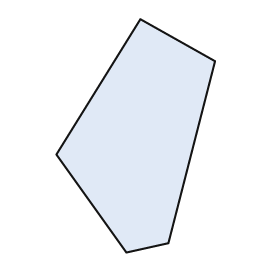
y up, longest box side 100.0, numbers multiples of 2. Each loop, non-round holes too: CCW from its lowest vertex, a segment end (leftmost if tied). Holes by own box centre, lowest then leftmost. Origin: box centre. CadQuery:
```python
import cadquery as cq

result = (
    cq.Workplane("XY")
    .moveTo(-4.0, -50.0)
    .lineTo(14.0, -46.0)
    .lineTo(34.0, 32.0)
    .lineTo(2.0, 50.0)
    .lineTo(-34.0, -8.0)
    .close()
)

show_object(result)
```